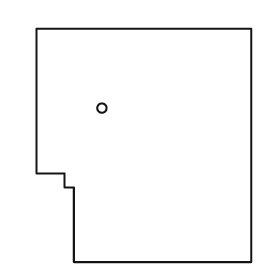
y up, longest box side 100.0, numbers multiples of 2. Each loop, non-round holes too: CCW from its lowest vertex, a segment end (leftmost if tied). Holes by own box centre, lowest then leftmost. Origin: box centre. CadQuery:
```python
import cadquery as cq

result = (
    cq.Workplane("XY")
    .moveTo(-30.0, -50.0)
    .lineTo(46.0, -50.0)
    .lineTo(46.0, 50.0)
    .lineTo(-46.0, 50.0)
    .lineTo(-46.0, -12.0)
    .lineTo(-34.0, -12.0)
    .lineTo(-34.0, -18.0)
    .lineTo(-30.0, -18.0)
    .close()
    .moveTo(-18.0, 16.0)
    .circle(2.0)
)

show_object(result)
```